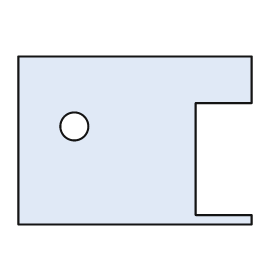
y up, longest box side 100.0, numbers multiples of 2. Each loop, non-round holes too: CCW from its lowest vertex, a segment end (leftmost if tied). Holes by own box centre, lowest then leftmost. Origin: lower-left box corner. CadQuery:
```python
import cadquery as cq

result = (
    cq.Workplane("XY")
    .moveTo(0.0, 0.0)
    .lineTo(100.0, 0.0)
    .lineTo(100.0, 4.0)
    .lineTo(76.0, 4.0)
    .lineTo(76.0, 52.0)
    .lineTo(100.0, 52.0)
    .lineTo(100.0, 72.0)
    .lineTo(0.0, 72.0)
    .close()
    .moveTo(24.0, 42.0)
    .circle(6.0)
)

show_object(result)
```